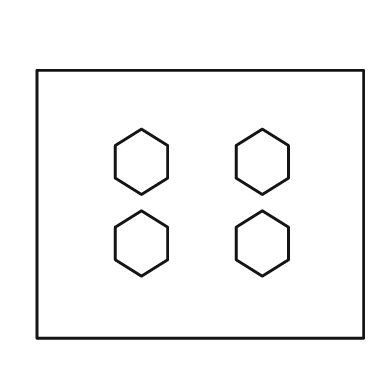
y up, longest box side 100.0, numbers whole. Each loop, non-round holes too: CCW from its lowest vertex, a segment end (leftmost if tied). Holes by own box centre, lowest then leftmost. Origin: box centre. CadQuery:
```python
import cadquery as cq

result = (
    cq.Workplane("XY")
    .moveTo(-50.0, -41.0)
    .lineTo(50.0, -41.0)
    .lineTo(50.0, 41.0)
    .lineTo(-50.0, 41.0)
    .close()
    .moveTo(-18.0, -22.0)
    .lineTo(-10.0, -17.0)
    .lineTo(-10.0, -7.0)
    .lineTo(-18.0, -2.0)
    .lineTo(-26.0, -7.0)
    .lineTo(-26.0, -17.0)
    .close()
    .moveTo(19.0, -22.0)
    .lineTo(27.0, -17.0)
    .lineTo(27.0, -7.0)
    .lineTo(19.0, -2.0)
    .lineTo(11.0, -7.0)
    .lineTo(11.0, -17.0)
    .close()
    .moveTo(-18.0, 3.0)
    .lineTo(-10.0, 8.0)
    .lineTo(-10.0, 18.0)
    .lineTo(-18.0, 23.0)
    .lineTo(-26.0, 18.0)
    .lineTo(-26.0, 8.0)
    .close()
    .moveTo(19.0, 3.0)
    .lineTo(27.0, 8.0)
    .lineTo(27.0, 18.0)
    .lineTo(19.0, 23.0)
    .lineTo(11.0, 18.0)
    .lineTo(11.0, 8.0)
    .close()
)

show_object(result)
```